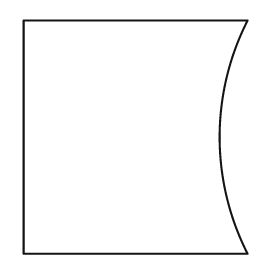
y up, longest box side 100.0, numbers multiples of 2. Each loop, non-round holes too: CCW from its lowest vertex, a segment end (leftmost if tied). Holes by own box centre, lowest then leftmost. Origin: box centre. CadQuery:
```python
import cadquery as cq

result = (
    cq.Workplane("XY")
    .moveTo(-48.0, -50.0)
    .lineTo(48.0, -50.0)
    .threePointArc((36.0, 0.0), (48.0, 50.0))
    .lineTo(-48.0, 50.0)
    .close()
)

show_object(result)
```